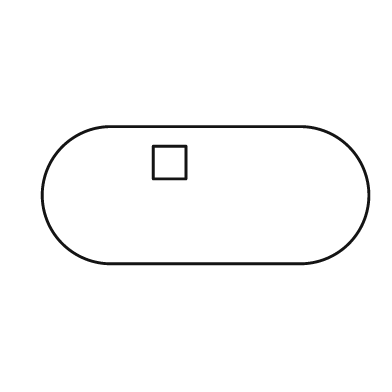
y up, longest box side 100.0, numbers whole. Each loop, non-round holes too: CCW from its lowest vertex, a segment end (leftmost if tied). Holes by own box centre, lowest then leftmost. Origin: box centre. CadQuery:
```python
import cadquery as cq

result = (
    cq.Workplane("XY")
    .moveTo(-29.0, -21.0)
    .lineTo(29.0, -21.0)
    .threePointArc((50.0, 0.0), (29.0, 21.0))
    .lineTo(-29.0, 21.0)
    .threePointArc((-50.0, 0.0), (-29.0, -21.0))
    .close()
    .moveTo(-16.0, 5.0)
    .lineTo(-6.0, 5.0)
    .lineTo(-6.0, 15.0)
    .lineTo(-16.0, 15.0)
    .close()
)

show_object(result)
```